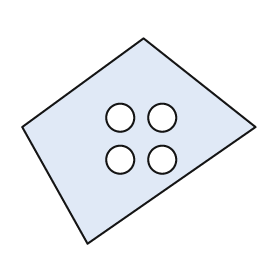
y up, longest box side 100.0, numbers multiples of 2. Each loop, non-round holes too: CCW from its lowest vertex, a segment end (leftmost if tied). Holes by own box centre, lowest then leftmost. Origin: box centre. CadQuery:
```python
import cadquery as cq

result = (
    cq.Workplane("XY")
    .moveTo(-22.0, -44.0)
    .lineTo(50.0, 6.0)
    .lineTo(2.0, 44.0)
    .lineTo(-50.0, 6.0)
    .close()
    .moveTo(-8.0, -8.0)
    .circle(6.0)
    .moveTo(10.0, -8.0)
    .circle(6.0)
    .moveTo(-8.0, 10.0)
    .circle(6.0)
    .moveTo(10.0, 10.0)
    .circle(6.0)
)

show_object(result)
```